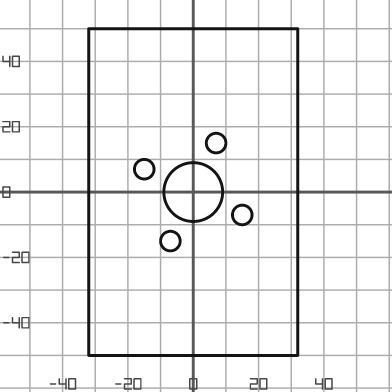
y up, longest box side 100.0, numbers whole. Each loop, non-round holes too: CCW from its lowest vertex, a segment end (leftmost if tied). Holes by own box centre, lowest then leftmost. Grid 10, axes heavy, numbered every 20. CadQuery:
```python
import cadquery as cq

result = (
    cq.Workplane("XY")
    .moveTo(-32.0, -50.0)
    .lineTo(32.0, -50.0)
    .lineTo(32.0, 50.0)
    .lineTo(-32.0, 50.0)
    .close()
    .moveTo(-7.0, -15.0)
    .circle(3.0)
    .moveTo(15.0, -7.0)
    .circle(3.0)
    .moveTo(0.0, 0.0)
    .circle(9.0)
    .moveTo(-15.0, 7.0)
    .circle(3.0)
    .moveTo(7.0, 15.0)
    .circle(3.0)
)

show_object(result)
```